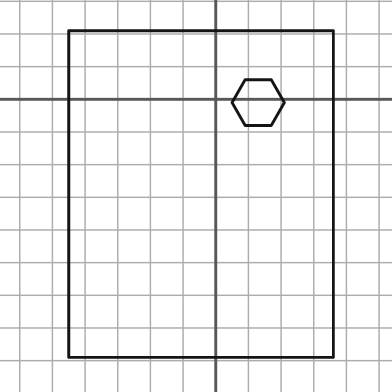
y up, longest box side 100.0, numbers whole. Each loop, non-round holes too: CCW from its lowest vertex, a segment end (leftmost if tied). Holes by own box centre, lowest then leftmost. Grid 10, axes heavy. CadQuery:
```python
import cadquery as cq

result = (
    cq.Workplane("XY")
    .moveTo(-45.0, -79.0)
    .lineTo(36.0, -79.0)
    .lineTo(36.0, 21.0)
    .lineTo(-45.0, 21.0)
    .close()
    .moveTo(9.0, -8.0)
    .lineTo(17.0, -8.0)
    .lineTo(21.0, -1.0)
    .lineTo(17.0, 6.0)
    .lineTo(9.0, 6.0)
    .lineTo(5.0, -1.0)
    .close()
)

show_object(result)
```